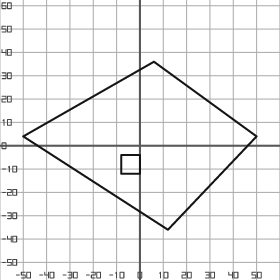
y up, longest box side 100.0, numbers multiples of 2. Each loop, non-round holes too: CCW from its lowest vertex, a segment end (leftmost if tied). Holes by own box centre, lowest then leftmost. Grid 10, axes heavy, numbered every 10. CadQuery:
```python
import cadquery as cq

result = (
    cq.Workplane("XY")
    .moveTo(12.0, -36.0)
    .lineTo(50.0, 4.0)
    .lineTo(6.0, 36.0)
    .lineTo(-50.0, 4.0)
    .close()
    .moveTo(-8.0, -12.0)
    .lineTo(0.0, -12.0)
    .lineTo(0.0, -4.0)
    .lineTo(-8.0, -4.0)
    .close()
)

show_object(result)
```